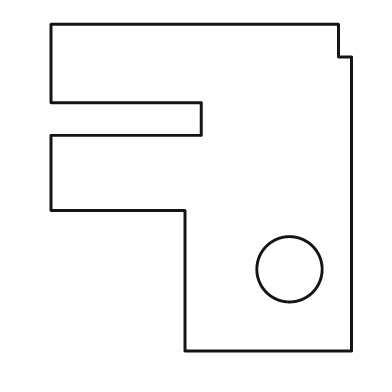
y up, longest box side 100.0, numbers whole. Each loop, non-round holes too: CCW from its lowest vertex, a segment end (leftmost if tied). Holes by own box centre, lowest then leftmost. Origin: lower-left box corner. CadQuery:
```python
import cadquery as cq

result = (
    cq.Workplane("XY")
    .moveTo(41.0, 0.0)
    .lineTo(92.0, 0.0)
    .lineTo(92.0, 90.0)
    .lineTo(88.0, 90.0)
    .lineTo(88.0, 100.0)
    .lineTo(0.0, 100.0)
    .lineTo(0.0, 76.0)
    .lineTo(46.0, 76.0)
    .lineTo(46.0, 66.0)
    .lineTo(0.0, 66.0)
    .lineTo(0.0, 43.0)
    .lineTo(41.0, 43.0)
    .close()
    .moveTo(73.0, 25.0)
    .circle(10.0)
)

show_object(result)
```